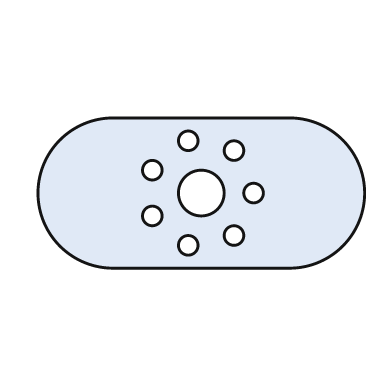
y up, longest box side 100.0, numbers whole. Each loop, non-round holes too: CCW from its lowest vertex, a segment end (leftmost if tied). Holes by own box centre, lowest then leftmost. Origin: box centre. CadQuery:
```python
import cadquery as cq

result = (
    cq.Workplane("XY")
    .moveTo(-27.0, -23.0)
    .lineTo(27.0, -23.0)
    .threePointArc((50.0, 0.0), (27.0, 23.0))
    .lineTo(-27.0, 23.0)
    .threePointArc((-50.0, 0.0), (-27.0, -23.0))
    .close()
    .moveTo(-4.0, -16.0)
    .circle(3.0)
    .moveTo(10.0, -13.0)
    .circle(3.0)
    .moveTo(-15.0, -7.0)
    .circle(3.0)
    .moveTo(0.0, 0.0)
    .circle(7.0)
    .moveTo(16.0, 0.0)
    .circle(3.0)
    .moveTo(-15.0, 7.0)
    .circle(3.0)
    .moveTo(10.0, 13.0)
    .circle(3.0)
    .moveTo(-4.0, 16.0)
    .circle(3.0)
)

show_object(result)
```